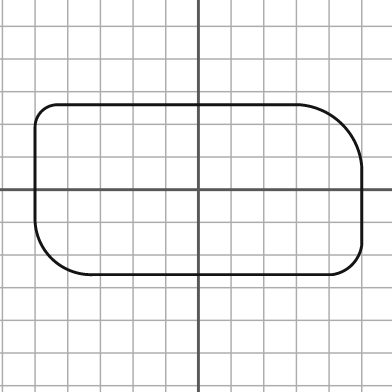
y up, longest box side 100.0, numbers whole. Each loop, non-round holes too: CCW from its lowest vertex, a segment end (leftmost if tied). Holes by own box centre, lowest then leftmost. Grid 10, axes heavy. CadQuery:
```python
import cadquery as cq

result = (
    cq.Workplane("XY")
    .moveTo(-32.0, -26.0)
    .lineTo(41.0, -26.0)
    .threePointArc((47.0, -23.0), (50.0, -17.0))
    .lineTo(50.0, 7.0)
    .threePointArc((44.0, 20.0), (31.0, 26.0))
    .lineTo(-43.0, 26.0)
    .threePointArc((-48.0, 24.0), (-50.0, 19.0))
    .lineTo(-50.0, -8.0)
    .threePointArc((-45.0, -21.0), (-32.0, -26.0))
    .close()
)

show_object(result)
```